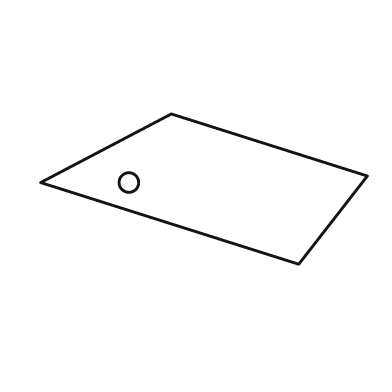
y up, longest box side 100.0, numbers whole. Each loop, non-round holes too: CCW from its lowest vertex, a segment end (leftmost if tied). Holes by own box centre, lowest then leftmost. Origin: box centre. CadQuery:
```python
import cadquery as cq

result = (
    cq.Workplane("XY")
    .moveTo(29.0, -23.0)
    .lineTo(50.0, 4.0)
    .lineTo(-10.0, 23.0)
    .lineTo(-50.0, 2.0)
    .close()
    .moveTo(-23.0, 2.0)
    .circle(3.0)
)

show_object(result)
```